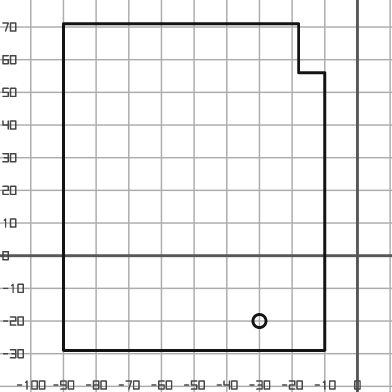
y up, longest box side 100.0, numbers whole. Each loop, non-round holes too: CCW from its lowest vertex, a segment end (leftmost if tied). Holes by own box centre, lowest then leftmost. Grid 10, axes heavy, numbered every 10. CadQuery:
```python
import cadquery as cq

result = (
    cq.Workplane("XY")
    .moveTo(-90.0, -29.0)
    .lineTo(-10.0, -29.0)
    .lineTo(-10.0, 56.0)
    .lineTo(-18.0, 56.0)
    .lineTo(-18.0, 71.0)
    .lineTo(-90.0, 71.0)
    .close()
    .moveTo(-30.0, -20.0)
    .circle(2.0)
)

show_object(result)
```